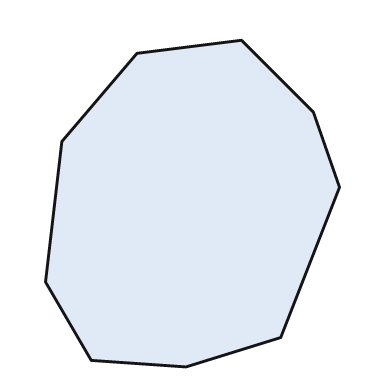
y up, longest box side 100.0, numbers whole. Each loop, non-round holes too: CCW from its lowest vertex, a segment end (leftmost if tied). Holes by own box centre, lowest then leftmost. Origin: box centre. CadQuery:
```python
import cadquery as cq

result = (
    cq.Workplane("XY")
    .moveTo(-2.0, -50.0)
    .lineTo(27.0, -41.0)
    .lineTo(45.0, 5.0)
    .lineTo(37.0, 28.0)
    .lineTo(15.0, 50.0)
    .lineTo(-17.0, 46.0)
    .lineTo(-40.0, 19.0)
    .lineTo(-45.0, -24.0)
    .lineTo(-31.0, -48.0)
    .close()
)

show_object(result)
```